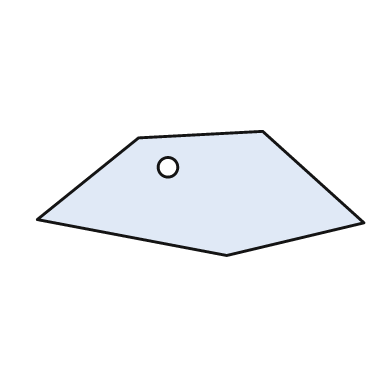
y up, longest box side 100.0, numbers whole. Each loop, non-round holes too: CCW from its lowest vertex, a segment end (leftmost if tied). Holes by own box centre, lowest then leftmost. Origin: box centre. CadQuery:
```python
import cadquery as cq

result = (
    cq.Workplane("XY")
    .moveTo(8.0, -19.0)
    .lineTo(50.0, -9.0)
    .lineTo(19.0, 19.0)
    .lineTo(-19.0, 17.0)
    .lineTo(-50.0, -8.0)
    .close()
    .moveTo(-10.0, 8.0)
    .circle(3.0)
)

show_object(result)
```